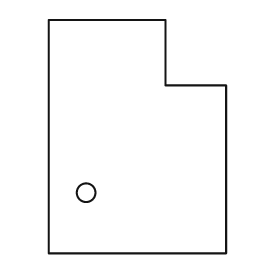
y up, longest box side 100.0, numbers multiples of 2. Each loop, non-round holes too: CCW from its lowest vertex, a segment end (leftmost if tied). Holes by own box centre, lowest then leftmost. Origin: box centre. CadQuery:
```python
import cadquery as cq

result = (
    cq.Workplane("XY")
    .moveTo(-38.0, -50.0)
    .lineTo(38.0, -50.0)
    .lineTo(38.0, 22.0)
    .lineTo(12.0, 22.0)
    .lineTo(12.0, 50.0)
    .lineTo(-38.0, 50.0)
    .close()
    .moveTo(-22.0, -24.0)
    .circle(4.0)
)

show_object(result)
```